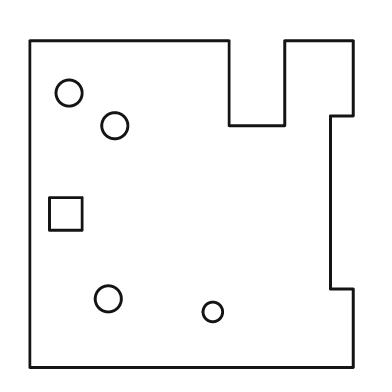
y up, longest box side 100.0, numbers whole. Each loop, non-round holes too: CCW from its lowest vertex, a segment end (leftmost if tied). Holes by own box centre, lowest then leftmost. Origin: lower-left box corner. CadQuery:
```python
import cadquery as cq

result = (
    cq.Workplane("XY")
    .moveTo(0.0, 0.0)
    .lineTo(99.0, 0.0)
    .lineTo(99.0, 24.0)
    .lineTo(92.0, 24.0)
    .lineTo(92.0, 77.0)
    .lineTo(99.0, 77.0)
    .lineTo(99.0, 100.0)
    .lineTo(78.0, 100.0)
    .lineTo(78.0, 74.0)
    .lineTo(61.0, 74.0)
    .lineTo(61.0, 100.0)
    .lineTo(0.0, 100.0)
    .close()
    .moveTo(56.0, 17.0)
    .circle(3.0)
    .moveTo(24.0, 21.0)
    .circle(4.0)
    .moveTo(6.0, 42.0)
    .lineTo(16.0, 42.0)
    .lineTo(16.0, 52.0)
    .lineTo(6.0, 52.0)
    .close()
    .moveTo(26.0, 74.0)
    .circle(4.0)
    .moveTo(12.0, 84.0)
    .circle(4.0)
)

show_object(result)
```